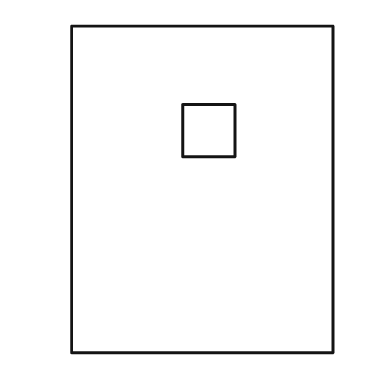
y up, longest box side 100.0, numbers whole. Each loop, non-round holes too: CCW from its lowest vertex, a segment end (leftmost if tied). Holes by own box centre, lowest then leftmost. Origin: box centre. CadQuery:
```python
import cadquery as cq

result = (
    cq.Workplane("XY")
    .moveTo(-40.0, -50.0)
    .lineTo(40.0, -50.0)
    .lineTo(40.0, 50.0)
    .lineTo(-40.0, 50.0)
    .close()
    .moveTo(-6.0, 10.0)
    .lineTo(10.0, 10.0)
    .lineTo(10.0, 26.0)
    .lineTo(-6.0, 26.0)
    .close()
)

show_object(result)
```